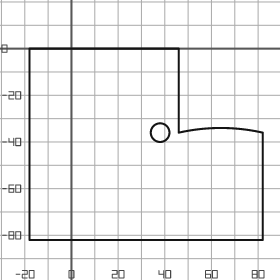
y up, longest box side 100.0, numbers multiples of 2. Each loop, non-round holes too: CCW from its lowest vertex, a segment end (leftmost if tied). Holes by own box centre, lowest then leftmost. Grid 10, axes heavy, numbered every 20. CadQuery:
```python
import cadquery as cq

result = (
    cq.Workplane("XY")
    .moveTo(-18.0, -82.0)
    .lineTo(82.0, -82.0)
    .lineTo(82.0, -36.0)
    .threePointArc((64.0, -34.0), (46.0, -36.0))
    .lineTo(46.0, 0.0)
    .lineTo(-18.0, 0.0)
    .close()
    .moveTo(38.0, -36.0)
    .circle(4.0)
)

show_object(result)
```